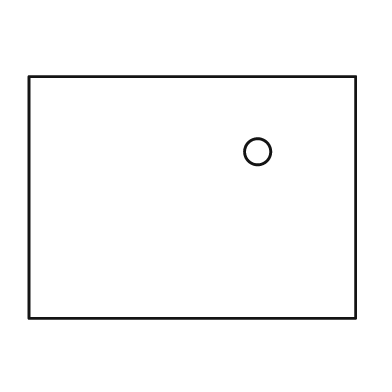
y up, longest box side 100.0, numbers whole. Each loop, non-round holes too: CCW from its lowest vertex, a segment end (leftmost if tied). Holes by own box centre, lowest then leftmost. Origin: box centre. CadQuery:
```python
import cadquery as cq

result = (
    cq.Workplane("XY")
    .moveTo(-50.0, -37.0)
    .lineTo(50.0, -37.0)
    .lineTo(50.0, 37.0)
    .lineTo(-50.0, 37.0)
    .close()
    .moveTo(20.0, 14.0)
    .circle(4.0)
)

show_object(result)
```